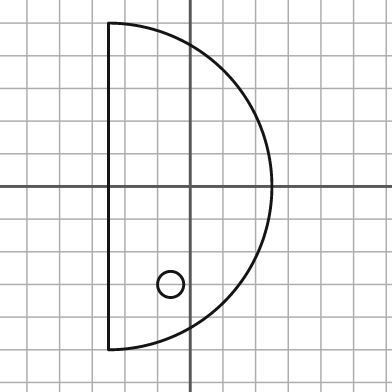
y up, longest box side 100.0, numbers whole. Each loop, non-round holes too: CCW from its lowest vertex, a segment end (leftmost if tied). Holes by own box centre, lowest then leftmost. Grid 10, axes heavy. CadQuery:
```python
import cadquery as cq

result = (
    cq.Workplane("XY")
    .moveTo(-25.0, -50.0)
    .threePointArc((25.0, 0.0), (-25.0, 50.0))
    .close()
    .moveTo(-6.0, -30.0)
    .circle(4.0)
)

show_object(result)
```